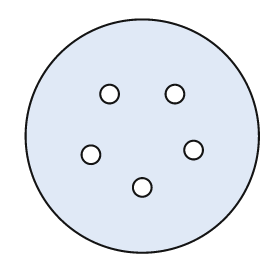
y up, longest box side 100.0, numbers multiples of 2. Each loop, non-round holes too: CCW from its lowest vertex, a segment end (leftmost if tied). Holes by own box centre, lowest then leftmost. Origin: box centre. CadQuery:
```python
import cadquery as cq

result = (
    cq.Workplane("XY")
    .moveTo(0.0, 0.0)
    .circle(50.0)
    .moveTo(0.0, -22.0)
    .circle(4.0)
    .moveTo(-22.0, -8.0)
    .circle(4.0)
    .moveTo(22.0, -6.0)
    .circle(4.0)
    .moveTo(-14.0, 18.0)
    .circle(4.0)
    .moveTo(14.0, 18.0)
    .circle(4.0)
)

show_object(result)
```